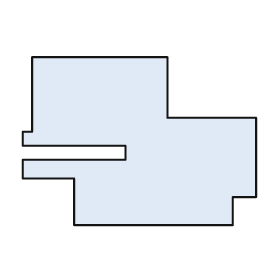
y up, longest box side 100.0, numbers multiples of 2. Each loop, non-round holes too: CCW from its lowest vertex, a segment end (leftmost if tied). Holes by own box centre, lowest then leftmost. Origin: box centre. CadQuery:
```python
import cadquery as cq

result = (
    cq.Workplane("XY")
    .moveTo(-28.0, -36.0)
    .lineTo(40.0, -36.0)
    .lineTo(40.0, -24.0)
    .lineTo(50.0, -24.0)
    .lineTo(50.0, 10.0)
    .lineTo(12.0, 10.0)
    .lineTo(12.0, 36.0)
    .lineTo(-46.0, 36.0)
    .lineTo(-46.0, 4.0)
    .lineTo(-50.0, 4.0)
    .lineTo(-50.0, -2.0)
    .lineTo(-6.0, -2.0)
    .lineTo(-6.0, -8.0)
    .lineTo(-50.0, -8.0)
    .lineTo(-50.0, -16.0)
    .lineTo(-28.0, -16.0)
    .close()
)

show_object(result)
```